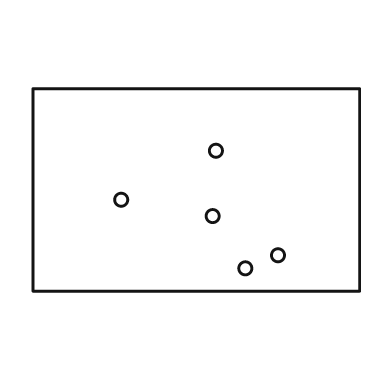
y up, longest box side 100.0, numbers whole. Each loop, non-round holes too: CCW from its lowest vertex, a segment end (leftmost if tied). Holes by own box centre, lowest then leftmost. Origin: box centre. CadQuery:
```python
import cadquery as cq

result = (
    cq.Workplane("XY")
    .moveTo(-50.0, -31.0)
    .lineTo(50.0, -31.0)
    .lineTo(50.0, 31.0)
    .lineTo(-50.0, 31.0)
    .close()
    .moveTo(15.0, -24.0)
    .circle(2.0)
    .moveTo(25.0, -20.0)
    .circle(2.0)
    .moveTo(5.0, -8.0)
    .circle(2.0)
    .moveTo(-23.0, -3.0)
    .circle(2.0)
    .moveTo(6.0, 12.0)
    .circle(2.0)
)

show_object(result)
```